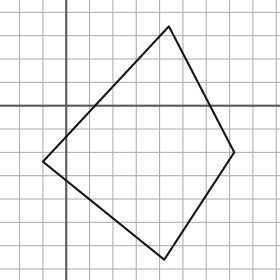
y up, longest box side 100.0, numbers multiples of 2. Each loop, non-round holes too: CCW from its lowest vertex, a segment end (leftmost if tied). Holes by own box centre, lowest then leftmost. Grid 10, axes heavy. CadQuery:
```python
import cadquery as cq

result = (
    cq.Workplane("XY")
    .moveTo(42.0, -66.0)
    .lineTo(72.0, -20.0)
    .lineTo(44.0, 34.0)
    .lineTo(-10.0, -24.0)
    .close()
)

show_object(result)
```